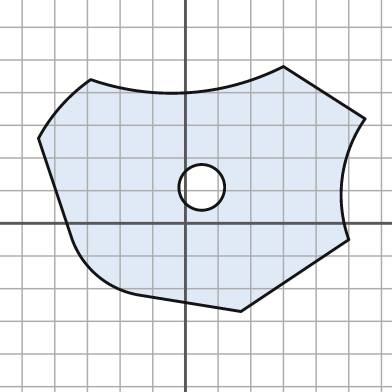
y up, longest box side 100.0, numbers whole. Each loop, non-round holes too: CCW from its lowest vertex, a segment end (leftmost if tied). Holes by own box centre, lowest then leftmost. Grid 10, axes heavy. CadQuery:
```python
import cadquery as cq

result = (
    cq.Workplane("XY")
    .moveTo(17.0, -27.0)
    .lineTo(50.0, -5.0)
    .threePointArc((48.0, 14.0), (55.0, 32.0))
    .lineTo(30.0, 48.0)
    .threePointArc((1.0, 40.0), (-29.0, 44.0))
    .threePointArc((-38.0, 36.0), (-45.0, 26.0))
    .lineTo(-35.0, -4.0)
    .threePointArc((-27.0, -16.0), (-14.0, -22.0))
    .close()
    .moveTo(5.0, 11.0)
    .circle(7.0)
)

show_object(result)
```